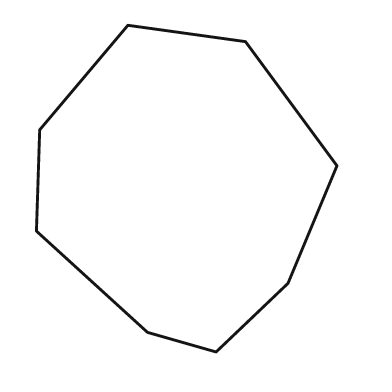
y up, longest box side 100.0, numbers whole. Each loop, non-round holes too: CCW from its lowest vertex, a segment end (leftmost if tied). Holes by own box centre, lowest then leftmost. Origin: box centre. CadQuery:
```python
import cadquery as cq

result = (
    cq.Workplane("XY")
    .moveTo(9.0, -50.0)
    .lineTo(31.0, -29.0)
    .lineTo(46.0, 7.0)
    .lineTo(18.0, 45.0)
    .lineTo(-18.0, 50.0)
    .lineTo(-45.0, 18.0)
    .lineTo(-46.0, -13.0)
    .lineTo(-12.0, -44.0)
    .close()
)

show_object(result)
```